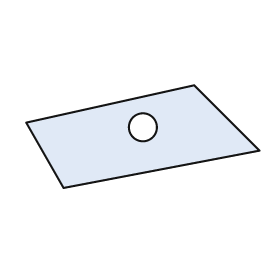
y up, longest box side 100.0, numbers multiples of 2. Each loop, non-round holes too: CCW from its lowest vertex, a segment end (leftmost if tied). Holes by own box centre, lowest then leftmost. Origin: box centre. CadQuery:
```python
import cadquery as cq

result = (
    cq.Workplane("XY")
    .moveTo(-34.0, -22.0)
    .lineTo(50.0, -6.0)
    .lineTo(22.0, 22.0)
    .lineTo(-50.0, 6.0)
    .close()
    .moveTo(0.0, 4.0)
    .circle(6.0)
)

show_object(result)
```